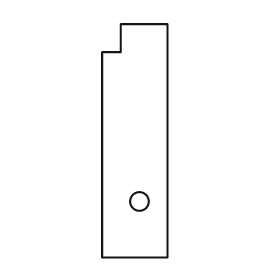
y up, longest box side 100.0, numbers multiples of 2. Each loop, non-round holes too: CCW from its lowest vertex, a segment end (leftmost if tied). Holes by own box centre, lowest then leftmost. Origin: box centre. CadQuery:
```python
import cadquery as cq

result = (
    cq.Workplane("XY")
    .moveTo(-14.0, -50.0)
    .lineTo(14.0, -50.0)
    .lineTo(14.0, 50.0)
    .lineTo(-6.0, 50.0)
    .lineTo(-6.0, 38.0)
    .lineTo(-14.0, 38.0)
    .close()
    .moveTo(2.0, -26.0)
    .circle(4.0)
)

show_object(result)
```